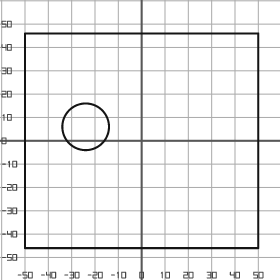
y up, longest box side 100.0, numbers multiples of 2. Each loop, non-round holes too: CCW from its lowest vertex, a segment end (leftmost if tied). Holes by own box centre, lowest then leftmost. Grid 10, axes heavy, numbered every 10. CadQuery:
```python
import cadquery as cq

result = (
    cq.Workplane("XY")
    .moveTo(-50.0, -46.0)
    .lineTo(50.0, -46.0)
    .lineTo(50.0, 46.0)
    .lineTo(-50.0, 46.0)
    .close()
    .moveTo(-24.0, 6.0)
    .circle(10.0)
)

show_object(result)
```